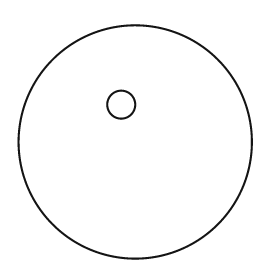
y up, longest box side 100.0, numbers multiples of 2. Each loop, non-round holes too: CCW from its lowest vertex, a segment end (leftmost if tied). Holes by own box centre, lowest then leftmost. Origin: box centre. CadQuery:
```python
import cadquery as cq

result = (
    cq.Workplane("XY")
    .moveTo(0.0, 0.0)
    .circle(50.0)
    .moveTo(-6.0, 16.0)
    .circle(6.0)
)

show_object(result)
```